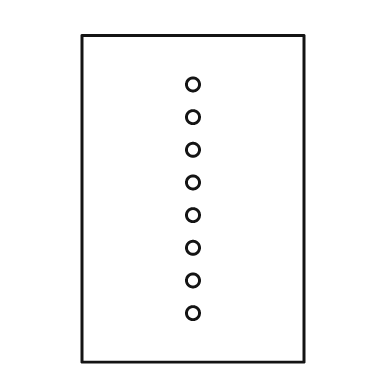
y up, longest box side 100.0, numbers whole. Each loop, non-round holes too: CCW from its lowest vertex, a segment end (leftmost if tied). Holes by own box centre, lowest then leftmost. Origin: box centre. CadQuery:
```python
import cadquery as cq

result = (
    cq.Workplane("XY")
    .moveTo(-34.0, -50.0)
    .lineTo(34.0, -50.0)
    .lineTo(34.0, 50.0)
    .lineTo(-34.0, 50.0)
    .close()
    .moveTo(0.0, -35.0)
    .circle(2.0)
    .moveTo(0.0, -25.0)
    .circle(2.0)
    .moveTo(0.0, -15.0)
    .circle(2.0)
    .moveTo(0.0, -5.0)
    .circle(2.0)
    .moveTo(0.0, 5.0)
    .circle(2.0)
    .moveTo(0.0, 15.0)
    .circle(2.0)
    .moveTo(0.0, 25.0)
    .circle(2.0)
    .moveTo(0.0, 35.0)
    .circle(2.0)
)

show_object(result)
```